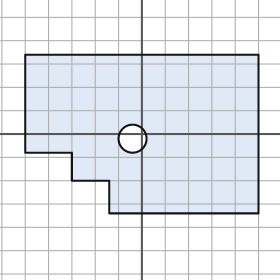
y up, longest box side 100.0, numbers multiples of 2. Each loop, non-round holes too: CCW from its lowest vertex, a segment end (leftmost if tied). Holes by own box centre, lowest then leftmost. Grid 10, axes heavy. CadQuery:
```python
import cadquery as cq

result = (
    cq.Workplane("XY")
    .moveTo(-14.0, -34.0)
    .lineTo(50.0, -34.0)
    .lineTo(50.0, 34.0)
    .lineTo(-50.0, 34.0)
    .lineTo(-50.0, -8.0)
    .lineTo(-30.0, -8.0)
    .lineTo(-30.0, -20.0)
    .lineTo(-14.0, -20.0)
    .close()
    .moveTo(-4.0, -2.0)
    .circle(6.0)
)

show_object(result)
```